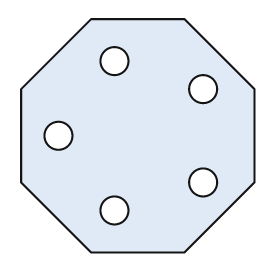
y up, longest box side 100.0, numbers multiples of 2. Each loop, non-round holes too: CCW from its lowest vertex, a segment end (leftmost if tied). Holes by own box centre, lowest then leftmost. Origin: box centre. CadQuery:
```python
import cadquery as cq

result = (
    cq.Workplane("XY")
    .moveTo(-20.0, -50.0)
    .lineTo(20.0, -50.0)
    .lineTo(50.0, -20.0)
    .lineTo(50.0, 20.0)
    .lineTo(20.0, 50.0)
    .lineTo(-20.0, 50.0)
    .lineTo(-50.0, 20.0)
    .lineTo(-50.0, -20.0)
    .close()
    .moveTo(-10.0, -32.0)
    .circle(6.0)
    .moveTo(28.0, -20.0)
    .circle(6.0)
    .moveTo(-34.0, 0.0)
    .circle(6.0)
    .moveTo(28.0, 20.0)
    .circle(6.0)
    .moveTo(-10.0, 32.0)
    .circle(6.0)
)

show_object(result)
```